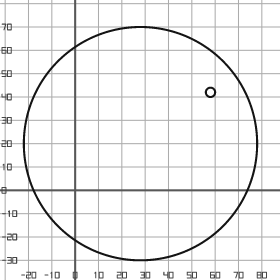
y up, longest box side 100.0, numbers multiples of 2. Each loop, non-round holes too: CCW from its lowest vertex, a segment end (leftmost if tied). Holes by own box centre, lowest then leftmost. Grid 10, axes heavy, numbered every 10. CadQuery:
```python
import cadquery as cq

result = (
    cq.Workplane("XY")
    .moveTo(28.0, 20.0)
    .circle(50.0)
    .moveTo(58.0, 42.0)
    .circle(2.0)
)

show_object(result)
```